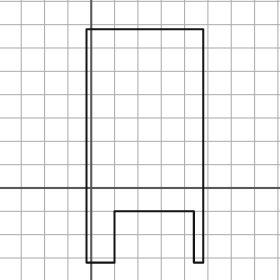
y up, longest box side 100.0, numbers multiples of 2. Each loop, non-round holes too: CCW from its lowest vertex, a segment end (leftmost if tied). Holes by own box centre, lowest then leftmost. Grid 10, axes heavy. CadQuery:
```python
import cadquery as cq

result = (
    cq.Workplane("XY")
    .moveTo(-2.0, -32.0)
    .lineTo(10.0, -32.0)
    .lineTo(10.0, -10.0)
    .lineTo(44.0, -10.0)
    .lineTo(44.0, -32.0)
    .lineTo(48.0, -32.0)
    .lineTo(48.0, 68.0)
    .lineTo(-2.0, 68.0)
    .close()
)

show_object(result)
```